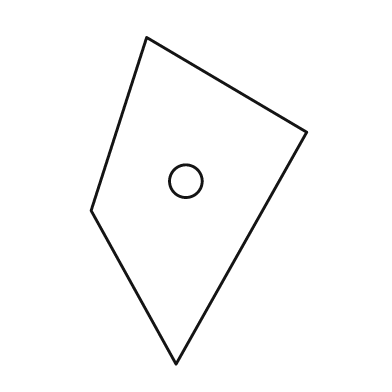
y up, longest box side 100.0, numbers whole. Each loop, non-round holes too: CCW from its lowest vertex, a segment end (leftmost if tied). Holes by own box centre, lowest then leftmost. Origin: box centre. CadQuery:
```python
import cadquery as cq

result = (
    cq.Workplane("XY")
    .moveTo(-7.0, -50.0)
    .lineTo(33.0, 21.0)
    .lineTo(-16.0, 50.0)
    .lineTo(-33.0, -3.0)
    .close()
    .moveTo(-4.0, 6.0)
    .circle(5.0)
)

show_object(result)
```